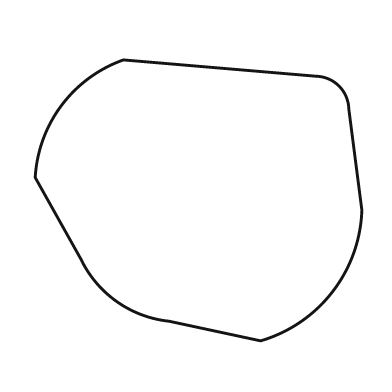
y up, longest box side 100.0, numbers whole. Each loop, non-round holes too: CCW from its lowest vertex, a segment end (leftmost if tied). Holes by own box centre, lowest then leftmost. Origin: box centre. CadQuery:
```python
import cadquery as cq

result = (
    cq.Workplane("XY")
    .moveTo(19.0, -43.0)
    .threePointArc((41.0, -28.0), (50.0, -3.0))
    .lineTo(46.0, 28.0)
    .threePointArc((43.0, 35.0), (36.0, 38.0))
    .lineTo(-23.0, 43.0)
    .threePointArc((-42.0, 29.0), (-50.0, 7.0))
    .lineTo(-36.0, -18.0)
    .threePointArc((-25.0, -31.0), (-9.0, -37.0))
    .close()
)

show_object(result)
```